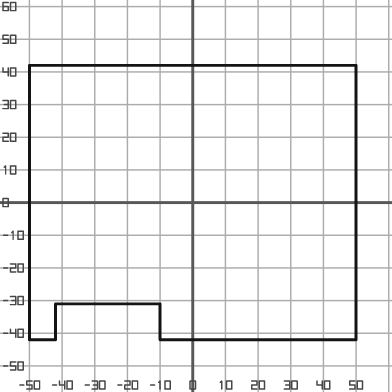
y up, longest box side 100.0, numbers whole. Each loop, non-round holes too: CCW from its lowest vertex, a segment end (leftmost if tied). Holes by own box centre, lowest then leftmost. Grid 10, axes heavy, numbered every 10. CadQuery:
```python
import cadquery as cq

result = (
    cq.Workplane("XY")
    .moveTo(-50.0, -42.0)
    .lineTo(-42.0, -42.0)
    .lineTo(-42.0, -31.0)
    .lineTo(-10.0, -31.0)
    .lineTo(-10.0, -42.0)
    .lineTo(50.0, -42.0)
    .lineTo(50.0, 42.0)
    .lineTo(-50.0, 42.0)
    .close()
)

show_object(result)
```